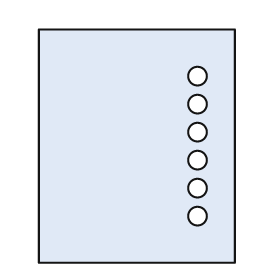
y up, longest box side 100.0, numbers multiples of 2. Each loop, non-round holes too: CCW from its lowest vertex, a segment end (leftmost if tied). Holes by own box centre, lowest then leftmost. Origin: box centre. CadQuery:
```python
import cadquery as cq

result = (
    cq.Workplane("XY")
    .moveTo(-42.0, -50.0)
    .lineTo(42.0, -50.0)
    .lineTo(42.0, 50.0)
    .lineTo(-42.0, 50.0)
    .close()
    .moveTo(26.0, -30.0)
    .circle(4.0)
    .moveTo(26.0, -18.0)
    .circle(4.0)
    .moveTo(26.0, -6.0)
    .circle(4.0)
    .moveTo(26.0, 6.0)
    .circle(4.0)
    .moveTo(26.0, 18.0)
    .circle(4.0)
    .moveTo(26.0, 30.0)
    .circle(4.0)
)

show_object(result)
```